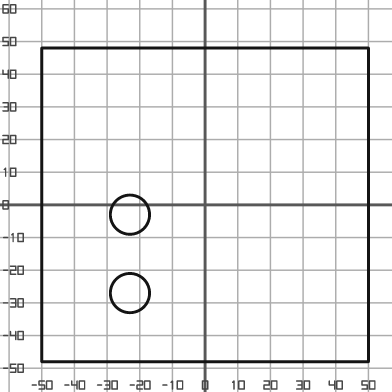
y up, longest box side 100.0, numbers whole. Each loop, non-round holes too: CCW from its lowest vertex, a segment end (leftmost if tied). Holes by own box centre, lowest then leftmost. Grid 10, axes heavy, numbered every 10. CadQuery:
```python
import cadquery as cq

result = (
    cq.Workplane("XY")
    .moveTo(-50.0, -48.0)
    .lineTo(50.0, -48.0)
    .lineTo(50.0, 48.0)
    .lineTo(-50.0, 48.0)
    .close()
    .moveTo(-23.0, -27.0)
    .circle(6.0)
    .moveTo(-23.0, -3.0)
    .circle(6.0)
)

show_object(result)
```